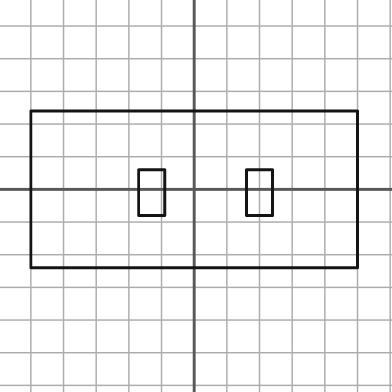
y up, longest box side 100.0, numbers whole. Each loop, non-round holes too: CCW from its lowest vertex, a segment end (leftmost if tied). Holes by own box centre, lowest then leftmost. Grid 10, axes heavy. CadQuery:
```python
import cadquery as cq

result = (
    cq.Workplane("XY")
    .moveTo(-50.0, -24.0)
    .lineTo(50.0, -24.0)
    .lineTo(50.0, 24.0)
    .lineTo(-50.0, 24.0)
    .close()
    .moveTo(-17.0, -8.0)
    .lineTo(-9.0, -8.0)
    .lineTo(-9.0, 6.0)
    .lineTo(-17.0, 6.0)
    .close()
    .moveTo(16.0, -8.0)
    .lineTo(24.0, -8.0)
    .lineTo(24.0, 6.0)
    .lineTo(16.0, 6.0)
    .close()
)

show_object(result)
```